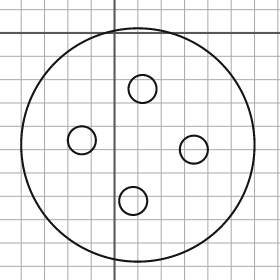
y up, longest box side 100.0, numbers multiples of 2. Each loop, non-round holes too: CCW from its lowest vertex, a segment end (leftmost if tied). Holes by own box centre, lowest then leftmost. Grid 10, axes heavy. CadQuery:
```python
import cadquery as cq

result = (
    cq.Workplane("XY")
    .moveTo(10.0, -48.0)
    .circle(50.0)
    .moveTo(8.0, -72.0)
    .circle(6.0)
    .moveTo(34.0, -50.0)
    .circle(6.0)
    .moveTo(-14.0, -46.0)
    .circle(6.0)
    .moveTo(12.0, -24.0)
    .circle(6.0)
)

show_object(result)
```